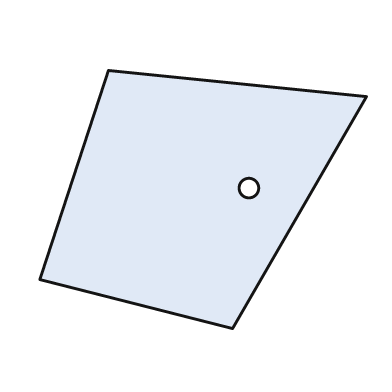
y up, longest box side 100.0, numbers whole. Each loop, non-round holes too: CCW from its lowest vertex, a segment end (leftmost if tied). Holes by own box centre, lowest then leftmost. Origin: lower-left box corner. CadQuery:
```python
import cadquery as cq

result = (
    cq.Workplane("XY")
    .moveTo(59.0, 0.0)
    .lineTo(100.0, 71.0)
    .lineTo(21.0, 79.0)
    .lineTo(0.0, 15.0)
    .close()
    .moveTo(64.0, 43.0)
    .circle(3.0)
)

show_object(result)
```